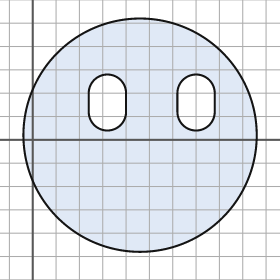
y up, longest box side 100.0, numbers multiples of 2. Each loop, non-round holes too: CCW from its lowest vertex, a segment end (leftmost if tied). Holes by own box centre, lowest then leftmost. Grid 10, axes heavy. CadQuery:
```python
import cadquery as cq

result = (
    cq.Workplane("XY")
    .moveTo(46.0, 2.0)
    .circle(50.0)
    .moveTo(24.0, 12.0)
    .threePointArc((32.0, 4.0), (40.0, 12.0))
    .lineTo(40.0, 20.0)
    .threePointArc((32.0, 28.0), (24.0, 20.0))
    .close()
    .moveTo(62.0, 12.0)
    .threePointArc((70.0, 4.0), (78.0, 12.0))
    .lineTo(78.0, 20.0)
    .threePointArc((70.0, 28.0), (62.0, 20.0))
    .close()
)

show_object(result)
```